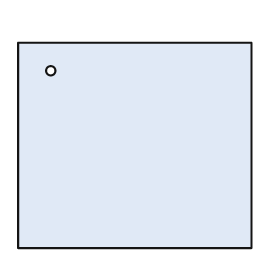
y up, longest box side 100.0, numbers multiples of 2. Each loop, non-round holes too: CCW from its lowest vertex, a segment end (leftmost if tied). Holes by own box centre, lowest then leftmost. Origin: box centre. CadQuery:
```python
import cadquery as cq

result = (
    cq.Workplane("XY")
    .moveTo(-50.0, -44.0)
    .lineTo(50.0, -44.0)
    .lineTo(50.0, 44.0)
    .lineTo(-50.0, 44.0)
    .close()
    .moveTo(-36.0, 32.0)
    .circle(2.0)
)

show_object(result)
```